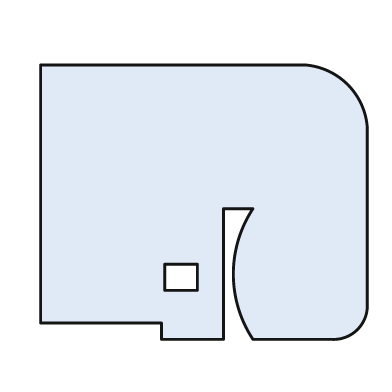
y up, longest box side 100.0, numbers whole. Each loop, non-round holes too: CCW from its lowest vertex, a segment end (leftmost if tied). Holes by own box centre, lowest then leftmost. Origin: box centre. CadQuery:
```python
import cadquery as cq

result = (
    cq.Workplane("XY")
    .moveTo(-13.0, -42.0)
    .lineTo(6.0, -42.0)
    .lineTo(6.0, -2.0)
    .lineTo(15.0, -2.0)
    .threePointArc((9.0, -22.0), (15.0, -42.0))
    .lineTo(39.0, -42.0)
    .threePointArc((47.0, -39.0), (50.0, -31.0))
    .lineTo(50.0, 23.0)
    .threePointArc((44.0, 36.0), (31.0, 42.0))
    .lineTo(-50.0, 42.0)
    .lineTo(-50.0, -37.0)
    .lineTo(-13.0, -37.0)
    .close()
    .moveTo(-12.0, -27.0)
    .lineTo(-2.0, -27.0)
    .lineTo(-2.0, -19.0)
    .lineTo(-12.0, -19.0)
    .close()
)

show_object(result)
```